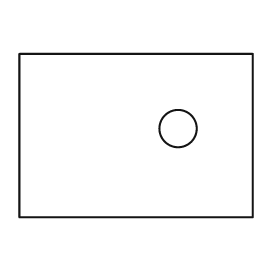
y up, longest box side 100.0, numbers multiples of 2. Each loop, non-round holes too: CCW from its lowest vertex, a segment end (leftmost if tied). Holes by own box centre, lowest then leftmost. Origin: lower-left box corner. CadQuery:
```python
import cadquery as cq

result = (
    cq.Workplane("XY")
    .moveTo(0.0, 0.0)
    .lineTo(100.0, 0.0)
    .lineTo(100.0, 70.0)
    .lineTo(0.0, 70.0)
    .close()
    .moveTo(68.0, 38.0)
    .circle(8.0)
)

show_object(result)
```